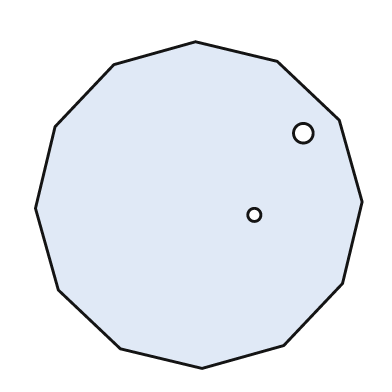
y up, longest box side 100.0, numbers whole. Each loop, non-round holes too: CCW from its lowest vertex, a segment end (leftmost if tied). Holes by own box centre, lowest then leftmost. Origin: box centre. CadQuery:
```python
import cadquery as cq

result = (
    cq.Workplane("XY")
    .moveTo(1.0, -50.0)
    .lineTo(26.0, -43.0)
    .lineTo(44.0, -24.0)
    .lineTo(50.0, 1.0)
    .lineTo(43.0, 26.0)
    .lineTo(24.0, 44.0)
    .lineTo(-1.0, 50.0)
    .lineTo(-26.0, 43.0)
    .lineTo(-44.0, 24.0)
    .lineTo(-50.0, -1.0)
    .lineTo(-43.0, -26.0)
    .lineTo(-24.0, -44.0)
    .close()
    .moveTo(17.0, -3.0)
    .circle(2.0)
    .moveTo(32.0, 22.0)
    .circle(3.0)
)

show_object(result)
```